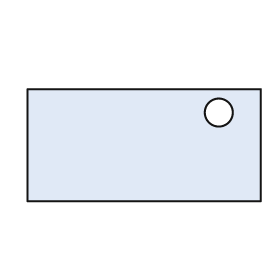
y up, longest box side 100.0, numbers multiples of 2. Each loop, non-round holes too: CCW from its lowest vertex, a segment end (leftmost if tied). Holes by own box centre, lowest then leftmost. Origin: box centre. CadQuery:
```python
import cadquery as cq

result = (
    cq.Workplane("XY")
    .moveTo(-50.0, -24.0)
    .lineTo(50.0, -24.0)
    .lineTo(50.0, 24.0)
    .lineTo(-50.0, 24.0)
    .close()
    .moveTo(32.0, 14.0)
    .circle(6.0)
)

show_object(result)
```